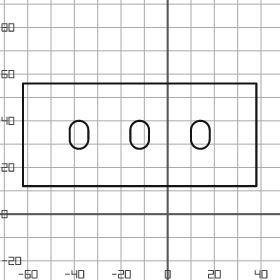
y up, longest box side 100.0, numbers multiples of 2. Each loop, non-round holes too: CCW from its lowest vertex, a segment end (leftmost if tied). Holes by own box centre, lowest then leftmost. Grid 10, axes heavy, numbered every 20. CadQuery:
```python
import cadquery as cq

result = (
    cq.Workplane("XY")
    .moveTo(-62.0, 12.0)
    .lineTo(38.0, 12.0)
    .lineTo(38.0, 56.0)
    .lineTo(-62.0, 56.0)
    .close()
    .moveTo(-42.0, 32.0)
    .threePointArc((-38.0, 28.0), (-34.0, 32.0))
    .lineTo(-34.0, 36.0)
    .threePointArc((-38.0, 40.0), (-42.0, 36.0))
    .close()
    .moveTo(-16.0, 32.0)
    .threePointArc((-12.0, 28.0), (-8.0, 32.0))
    .lineTo(-8.0, 36.0)
    .threePointArc((-12.0, 40.0), (-16.0, 36.0))
    .close()
    .moveTo(10.0, 32.0)
    .threePointArc((14.0, 28.0), (18.0, 32.0))
    .lineTo(18.0, 36.0)
    .threePointArc((14.0, 40.0), (10.0, 36.0))
    .close()
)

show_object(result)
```